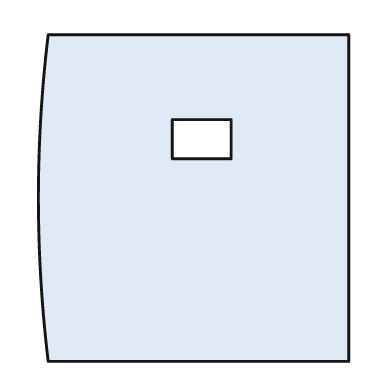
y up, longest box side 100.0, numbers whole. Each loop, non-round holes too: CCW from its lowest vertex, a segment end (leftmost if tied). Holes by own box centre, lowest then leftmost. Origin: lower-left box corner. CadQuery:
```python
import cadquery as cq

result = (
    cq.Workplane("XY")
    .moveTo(3.0, 0.0)
    .lineTo(95.0, 0.0)
    .lineTo(95.0, 100.0)
    .lineTo(3.0, 100.0)
    .threePointArc((0.0, 50.0), (3.0, 0.0))
    .close()
    .moveTo(41.0, 62.0)
    .lineTo(59.0, 62.0)
    .lineTo(59.0, 74.0)
    .lineTo(41.0, 74.0)
    .close()
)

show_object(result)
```